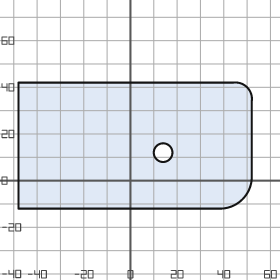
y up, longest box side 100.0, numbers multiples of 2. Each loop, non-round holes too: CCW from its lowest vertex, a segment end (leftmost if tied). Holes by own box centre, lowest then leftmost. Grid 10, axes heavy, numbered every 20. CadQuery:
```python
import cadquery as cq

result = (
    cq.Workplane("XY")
    .moveTo(-48.0, -12.0)
    .lineTo(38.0, -12.0)
    .threePointArc((48.0, -8.0), (52.0, 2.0))
    .lineTo(52.0, 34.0)
    .threePointArc((50.0, 40.0), (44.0, 42.0))
    .lineTo(-48.0, 42.0)
    .close()
    .moveTo(14.0, 12.0)
    .circle(4.0)
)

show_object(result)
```